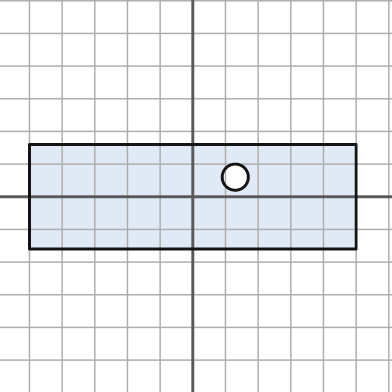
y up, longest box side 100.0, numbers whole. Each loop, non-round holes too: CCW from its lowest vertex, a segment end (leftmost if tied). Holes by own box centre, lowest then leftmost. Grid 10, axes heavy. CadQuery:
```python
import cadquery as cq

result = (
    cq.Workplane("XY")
    .moveTo(-50.0, -16.0)
    .lineTo(50.0, -16.0)
    .lineTo(50.0, 16.0)
    .lineTo(-50.0, 16.0)
    .close()
    .moveTo(13.0, 6.0)
    .circle(4.0)
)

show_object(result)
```